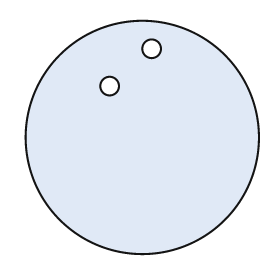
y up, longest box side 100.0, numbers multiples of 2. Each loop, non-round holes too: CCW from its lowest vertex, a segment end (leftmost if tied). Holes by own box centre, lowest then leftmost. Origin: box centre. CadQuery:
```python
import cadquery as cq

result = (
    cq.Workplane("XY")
    .moveTo(0.0, 0.0)
    .circle(50.0)
    .moveTo(-14.0, 22.0)
    .circle(4.0)
    .moveTo(4.0, 38.0)
    .circle(4.0)
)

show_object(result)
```